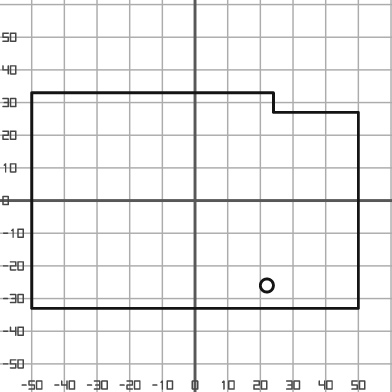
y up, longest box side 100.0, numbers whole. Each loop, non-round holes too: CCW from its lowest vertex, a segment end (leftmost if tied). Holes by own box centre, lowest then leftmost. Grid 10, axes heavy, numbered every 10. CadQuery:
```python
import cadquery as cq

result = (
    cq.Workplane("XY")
    .moveTo(-50.0, -33.0)
    .lineTo(50.0, -33.0)
    .lineTo(50.0, 27.0)
    .lineTo(24.0, 27.0)
    .lineTo(24.0, 33.0)
    .lineTo(-50.0, 33.0)
    .close()
    .moveTo(22.0, -26.0)
    .circle(2.0)
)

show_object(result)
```